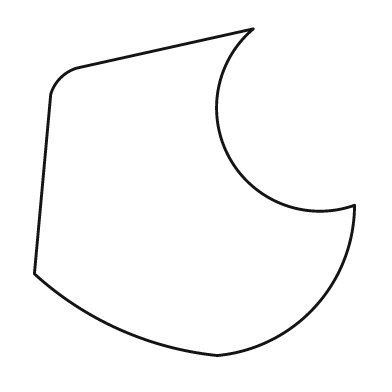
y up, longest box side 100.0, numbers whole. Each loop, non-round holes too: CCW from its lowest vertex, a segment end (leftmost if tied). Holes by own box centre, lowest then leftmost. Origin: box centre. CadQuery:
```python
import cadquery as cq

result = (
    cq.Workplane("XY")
    .moveTo(7.0, -50.0)
    .threePointArc((37.0, -35.0), (49.0, -4.0))
    .threePointArc((11.0, 10.0), (18.0, 50.0))
    .lineTo(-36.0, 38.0)
    .threePointArc((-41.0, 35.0), (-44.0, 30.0))
    .lineTo(-49.0, -25.0)
    .threePointArc((-23.0, -42.0), (7.0, -50.0))
    .close()
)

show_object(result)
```